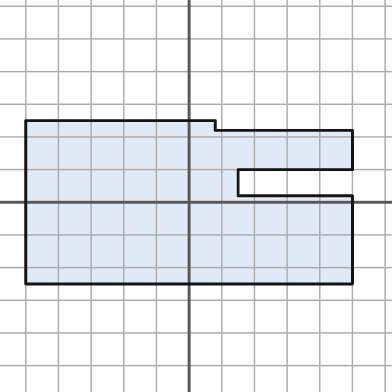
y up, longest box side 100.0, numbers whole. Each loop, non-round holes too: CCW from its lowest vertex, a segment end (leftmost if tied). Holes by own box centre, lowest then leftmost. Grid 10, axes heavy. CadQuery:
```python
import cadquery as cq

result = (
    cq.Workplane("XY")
    .moveTo(-50.0, -25.0)
    .lineTo(50.0, -25.0)
    .lineTo(50.0, 2.0)
    .lineTo(15.0, 2.0)
    .lineTo(15.0, 10.0)
    .lineTo(50.0, 10.0)
    .lineTo(50.0, 22.0)
    .lineTo(8.0, 22.0)
    .lineTo(8.0, 25.0)
    .lineTo(-50.0, 25.0)
    .close()
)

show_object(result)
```